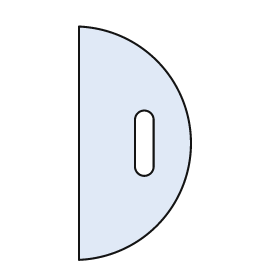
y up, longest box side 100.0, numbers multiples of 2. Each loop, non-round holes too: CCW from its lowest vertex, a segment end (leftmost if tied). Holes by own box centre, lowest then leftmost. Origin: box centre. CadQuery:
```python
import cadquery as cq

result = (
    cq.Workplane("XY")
    .moveTo(-24.0, -50.0)
    .threePointArc((24.0, 0.0), (-24.0, 50.0))
    .close()
    .moveTo(0.0, -10.0)
    .threePointArc((4.0, -14.0), (8.0, -10.0))
    .lineTo(8.0, 10.0)
    .threePointArc((4.0, 14.0), (0.0, 10.0))
    .close()
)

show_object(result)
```